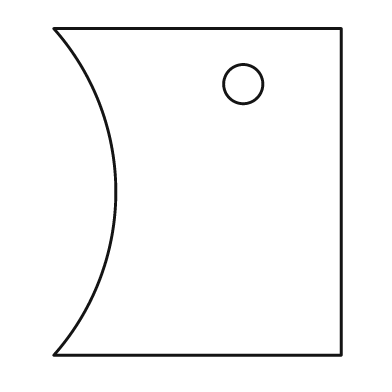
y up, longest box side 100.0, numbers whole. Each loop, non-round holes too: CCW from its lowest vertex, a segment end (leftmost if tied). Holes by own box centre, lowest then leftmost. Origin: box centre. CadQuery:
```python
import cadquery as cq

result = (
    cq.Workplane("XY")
    .moveTo(-44.0, -50.0)
    .lineTo(44.0, -50.0)
    .lineTo(44.0, 50.0)
    .lineTo(-44.0, 50.0)
    .threePointArc((-25.0, 0.0), (-44.0, -50.0))
    .close()
    .moveTo(14.0, 33.0)
    .circle(6.0)
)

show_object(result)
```